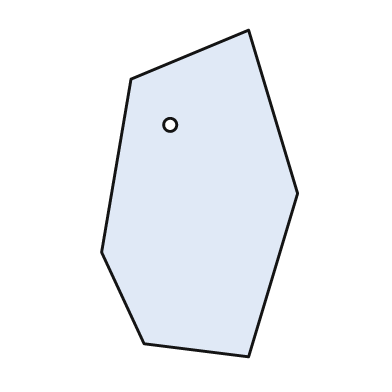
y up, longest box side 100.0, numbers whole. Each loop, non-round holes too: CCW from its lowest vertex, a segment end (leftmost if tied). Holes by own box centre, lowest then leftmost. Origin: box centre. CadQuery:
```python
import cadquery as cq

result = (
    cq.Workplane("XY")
    .moveTo(15.0, -50.0)
    .lineTo(30.0, 0.0)
    .lineTo(15.0, 50.0)
    .lineTo(-21.0, 35.0)
    .lineTo(-30.0, -18.0)
    .lineTo(-17.0, -46.0)
    .close()
    .moveTo(-9.0, 21.0)
    .circle(2.0)
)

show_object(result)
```